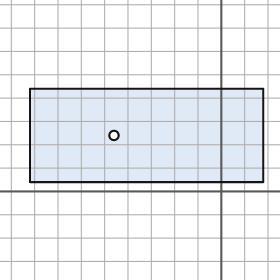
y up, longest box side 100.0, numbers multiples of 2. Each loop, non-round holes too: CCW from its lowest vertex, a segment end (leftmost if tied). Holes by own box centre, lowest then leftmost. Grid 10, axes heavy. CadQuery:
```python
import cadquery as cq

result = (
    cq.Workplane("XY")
    .moveTo(-82.0, 4.0)
    .lineTo(18.0, 4.0)
    .lineTo(18.0, 44.0)
    .lineTo(-82.0, 44.0)
    .close()
    .moveTo(-46.0, 24.0)
    .circle(2.0)
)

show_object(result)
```